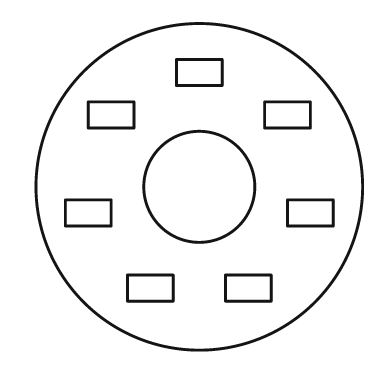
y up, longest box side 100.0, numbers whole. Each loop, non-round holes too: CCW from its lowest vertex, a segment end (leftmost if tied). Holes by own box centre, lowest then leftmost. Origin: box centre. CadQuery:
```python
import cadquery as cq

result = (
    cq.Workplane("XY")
    .moveTo(0.0, 0.0)
    .circle(50.0)
    .moveTo(-22.0, -35.0)
    .lineTo(-8.0, -35.0)
    .lineTo(-8.0, -27.0)
    .lineTo(-22.0, -27.0)
    .close()
    .moveTo(8.0, -35.0)
    .lineTo(22.0, -35.0)
    .lineTo(22.0, -27.0)
    .lineTo(8.0, -27.0)
    .close()
    .moveTo(-41.0, -12.0)
    .lineTo(-27.0, -12.0)
    .lineTo(-27.0, -4.0)
    .lineTo(-41.0, -4.0)
    .close()
    .moveTo(27.0, -12.0)
    .lineTo(41.0, -12.0)
    .lineTo(41.0, -4.0)
    .lineTo(27.0, -4.0)
    .close()
    .moveTo(0.0, 0.0)
    .circle(17.0)
    .moveTo(-34.0, 18.0)
    .lineTo(-20.0, 18.0)
    .lineTo(-20.0, 26.0)
    .lineTo(-34.0, 26.0)
    .close()
    .moveTo(20.0, 18.0)
    .lineTo(34.0, 18.0)
    .lineTo(34.0, 26.0)
    .lineTo(20.0, 26.0)
    .close()
    .moveTo(-7.0, 31.0)
    .lineTo(7.0, 31.0)
    .lineTo(7.0, 39.0)
    .lineTo(-7.0, 39.0)
    .close()
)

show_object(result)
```